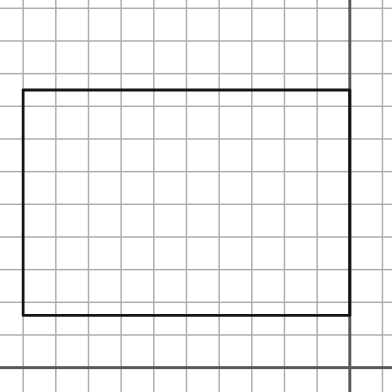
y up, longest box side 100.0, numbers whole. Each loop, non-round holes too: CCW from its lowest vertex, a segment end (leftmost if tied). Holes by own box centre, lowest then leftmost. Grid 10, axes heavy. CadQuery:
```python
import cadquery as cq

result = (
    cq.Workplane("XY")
    .moveTo(-100.0, 16.0)
    .lineTo(0.0, 16.0)
    .lineTo(0.0, 85.0)
    .lineTo(-100.0, 85.0)
    .close()
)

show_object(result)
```